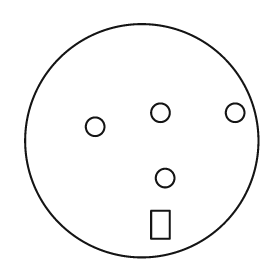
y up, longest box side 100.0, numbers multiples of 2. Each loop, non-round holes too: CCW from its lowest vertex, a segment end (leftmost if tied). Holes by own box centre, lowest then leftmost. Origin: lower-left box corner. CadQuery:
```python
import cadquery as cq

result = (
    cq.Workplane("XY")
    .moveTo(50.0, 50.0)
    .circle(50.0)
    .moveTo(54.0, 8.0)
    .lineTo(62.0, 8.0)
    .lineTo(62.0, 20.0)
    .lineTo(54.0, 20.0)
    .close()
    .moveTo(60.0, 34.0)
    .circle(4.0)
    .moveTo(30.0, 56.0)
    .circle(4.0)
    .moveTo(58.0, 62.0)
    .circle(4.0)
    .moveTo(90.0, 62.0)
    .circle(4.0)
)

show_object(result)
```